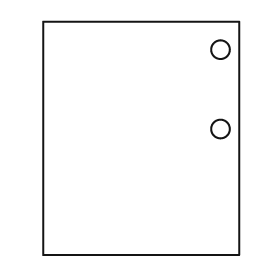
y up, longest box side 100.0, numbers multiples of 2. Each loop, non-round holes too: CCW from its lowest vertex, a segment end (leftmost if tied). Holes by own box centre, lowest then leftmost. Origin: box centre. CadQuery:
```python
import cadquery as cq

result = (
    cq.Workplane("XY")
    .moveTo(-42.0, -50.0)
    .lineTo(42.0, -50.0)
    .lineTo(42.0, 50.0)
    .lineTo(-42.0, 50.0)
    .close()
    .moveTo(34.0, 4.0)
    .circle(4.0)
    .moveTo(34.0, 38.0)
    .circle(4.0)
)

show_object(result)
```